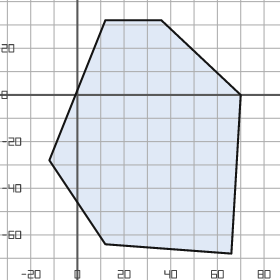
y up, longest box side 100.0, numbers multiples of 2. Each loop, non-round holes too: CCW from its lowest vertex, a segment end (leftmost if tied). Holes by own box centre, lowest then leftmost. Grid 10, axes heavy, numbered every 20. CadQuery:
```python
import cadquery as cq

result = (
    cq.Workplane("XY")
    .moveTo(66.0, -68.0)
    .lineTo(70.0, 0.0)
    .lineTo(36.0, 32.0)
    .lineTo(12.0, 32.0)
    .lineTo(-12.0, -28.0)
    .lineTo(12.0, -64.0)
    .close()
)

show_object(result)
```